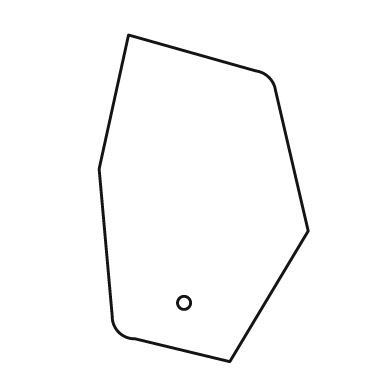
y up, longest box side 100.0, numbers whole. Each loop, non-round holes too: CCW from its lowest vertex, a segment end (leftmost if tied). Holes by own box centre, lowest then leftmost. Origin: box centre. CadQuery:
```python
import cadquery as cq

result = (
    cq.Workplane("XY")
    .moveTo(8.0, -50.0)
    .lineTo(32.0, -10.0)
    .lineTo(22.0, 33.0)
    .threePointArc((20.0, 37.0), (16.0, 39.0))
    .lineTo(-23.0, 50.0)
    .lineTo(-32.0, 9.0)
    .lineTo(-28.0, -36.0)
    .threePointArc((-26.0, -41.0), (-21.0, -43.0))
    .close()
    .moveTo(-6.0, -32.0)
    .circle(2.0)
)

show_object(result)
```